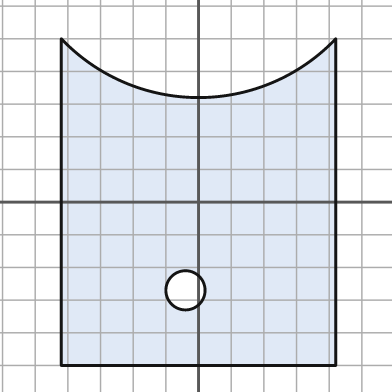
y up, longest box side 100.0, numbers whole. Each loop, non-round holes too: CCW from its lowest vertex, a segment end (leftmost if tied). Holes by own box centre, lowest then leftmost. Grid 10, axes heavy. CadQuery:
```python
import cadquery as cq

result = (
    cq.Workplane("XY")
    .moveTo(-42.0, -50.0)
    .lineTo(42.0, -50.0)
    .lineTo(42.0, 50.0)
    .threePointArc((0.0, 32.0), (-42.0, 50.0))
    .close()
    .moveTo(-4.0, -27.0)
    .circle(6.0)
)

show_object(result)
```